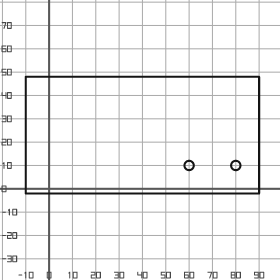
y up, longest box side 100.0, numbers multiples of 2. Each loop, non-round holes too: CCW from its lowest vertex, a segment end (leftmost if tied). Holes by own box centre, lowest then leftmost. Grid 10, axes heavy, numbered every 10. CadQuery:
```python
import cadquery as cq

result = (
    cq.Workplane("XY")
    .moveTo(-10.0, -2.0)
    .lineTo(90.0, -2.0)
    .lineTo(90.0, 48.0)
    .lineTo(-10.0, 48.0)
    .close()
    .moveTo(60.0, 10.0)
    .circle(2.0)
    .moveTo(80.0, 10.0)
    .circle(2.0)
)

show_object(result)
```